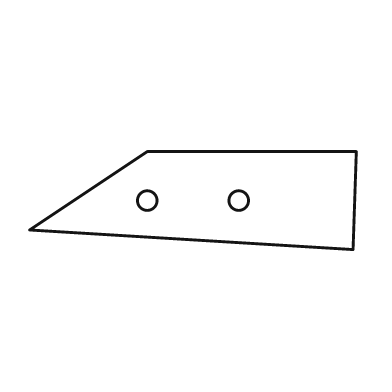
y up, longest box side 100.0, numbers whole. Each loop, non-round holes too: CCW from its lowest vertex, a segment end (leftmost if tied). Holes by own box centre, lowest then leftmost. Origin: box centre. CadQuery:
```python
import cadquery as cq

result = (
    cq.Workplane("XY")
    .moveTo(49.0, -15.0)
    .lineTo(50.0, 15.0)
    .lineTo(-14.0, 15.0)
    .lineTo(-50.0, -9.0)
    .close()
    .moveTo(-14.0, 0.0)
    .circle(3.0)
    .moveTo(14.0, 0.0)
    .circle(3.0)
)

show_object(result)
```